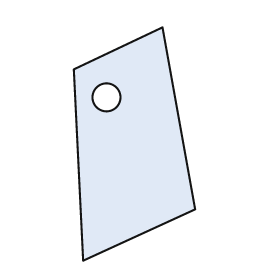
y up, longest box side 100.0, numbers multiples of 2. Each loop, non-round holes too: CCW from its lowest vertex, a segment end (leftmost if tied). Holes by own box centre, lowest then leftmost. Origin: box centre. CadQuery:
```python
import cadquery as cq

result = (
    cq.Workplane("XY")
    .moveTo(-22.0, -50.0)
    .lineTo(26.0, -28.0)
    .lineTo(12.0, 50.0)
    .lineTo(-26.0, 32.0)
    .close()
    .moveTo(-12.0, 20.0)
    .circle(6.0)
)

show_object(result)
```